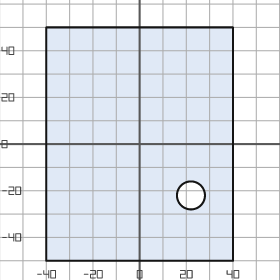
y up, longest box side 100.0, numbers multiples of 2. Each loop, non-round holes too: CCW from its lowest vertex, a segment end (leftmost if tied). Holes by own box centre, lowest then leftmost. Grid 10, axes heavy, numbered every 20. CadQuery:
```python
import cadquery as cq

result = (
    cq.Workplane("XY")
    .moveTo(-40.0, -50.0)
    .lineTo(40.0, -50.0)
    .lineTo(40.0, 50.0)
    .lineTo(-40.0, 50.0)
    .close()
    .moveTo(22.0, -22.0)
    .circle(6.0)
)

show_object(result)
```